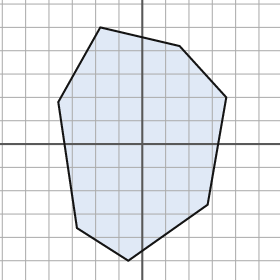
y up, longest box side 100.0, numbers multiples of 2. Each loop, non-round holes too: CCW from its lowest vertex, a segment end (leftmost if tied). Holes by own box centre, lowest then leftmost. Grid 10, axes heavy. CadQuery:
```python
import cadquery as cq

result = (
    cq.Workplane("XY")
    .moveTo(-6.0, -50.0)
    .lineTo(28.0, -26.0)
    .lineTo(36.0, 20.0)
    .lineTo(16.0, 42.0)
    .lineTo(-18.0, 50.0)
    .lineTo(-36.0, 18.0)
    .lineTo(-28.0, -36.0)
    .close()
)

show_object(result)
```